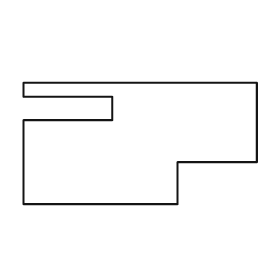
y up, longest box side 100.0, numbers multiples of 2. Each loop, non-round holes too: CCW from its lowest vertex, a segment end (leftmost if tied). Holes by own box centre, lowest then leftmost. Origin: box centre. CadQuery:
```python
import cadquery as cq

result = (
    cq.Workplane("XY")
    .moveTo(-50.0, -26.0)
    .lineTo(16.0, -26.0)
    .lineTo(16.0, -8.0)
    .lineTo(50.0, -8.0)
    .lineTo(50.0, 26.0)
    .lineTo(-50.0, 26.0)
    .lineTo(-50.0, 20.0)
    .lineTo(-12.0, 20.0)
    .lineTo(-12.0, 10.0)
    .lineTo(-50.0, 10.0)
    .close()
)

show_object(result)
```